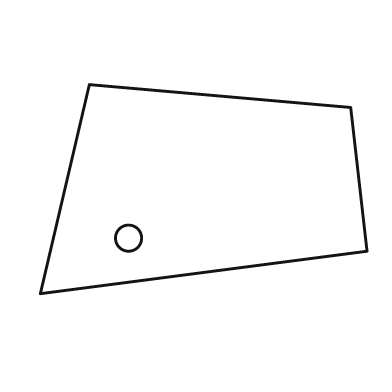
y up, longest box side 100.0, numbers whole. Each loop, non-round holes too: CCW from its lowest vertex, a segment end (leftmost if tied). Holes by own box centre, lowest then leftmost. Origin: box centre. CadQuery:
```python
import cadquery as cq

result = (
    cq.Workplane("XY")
    .moveTo(-50.0, -32.0)
    .lineTo(50.0, -19.0)
    .lineTo(45.0, 25.0)
    .lineTo(-35.0, 32.0)
    .close()
    .moveTo(-23.0, -15.0)
    .circle(4.0)
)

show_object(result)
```